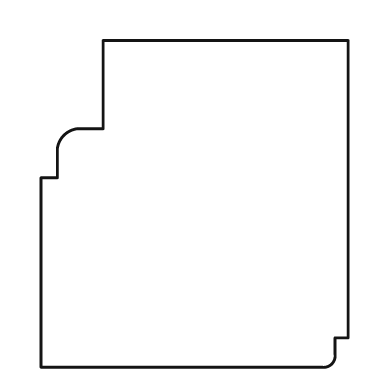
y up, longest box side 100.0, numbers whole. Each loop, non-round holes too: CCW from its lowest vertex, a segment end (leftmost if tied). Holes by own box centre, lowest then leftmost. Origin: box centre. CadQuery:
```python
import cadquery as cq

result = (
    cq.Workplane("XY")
    .moveTo(-47.0, -50.0)
    .lineTo(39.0, -50.0)
    .threePointArc((42.0, -49.0), (43.0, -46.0))
    .lineTo(43.0, -41.0)
    .lineTo(47.0, -41.0)
    .lineTo(47.0, 50.0)
    .lineTo(-28.0, 50.0)
    .lineTo(-28.0, 23.0)
    .lineTo(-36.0, 23.0)
    .threePointArc((-40.0, 21.0), (-42.0, 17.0))
    .lineTo(-42.0, 8.0)
    .lineTo(-47.0, 8.0)
    .close()
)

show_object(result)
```